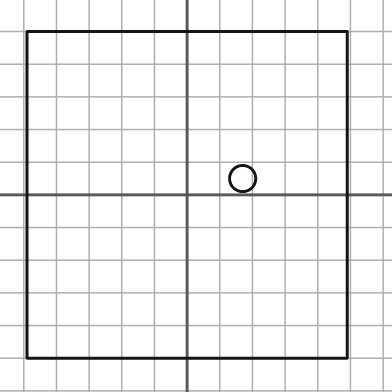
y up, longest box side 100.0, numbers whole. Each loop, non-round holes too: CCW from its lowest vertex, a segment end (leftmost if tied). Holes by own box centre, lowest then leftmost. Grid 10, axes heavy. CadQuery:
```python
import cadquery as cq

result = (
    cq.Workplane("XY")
    .moveTo(-49.0, -50.0)
    .lineTo(49.0, -50.0)
    .lineTo(49.0, 50.0)
    .lineTo(-49.0, 50.0)
    .close()
    .moveTo(17.0, 5.0)
    .circle(4.0)
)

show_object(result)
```